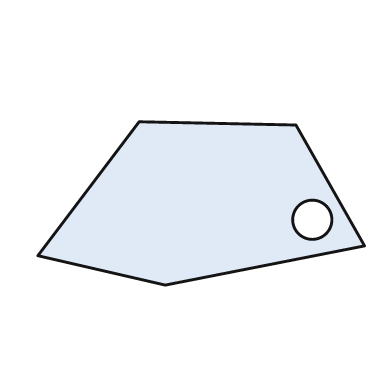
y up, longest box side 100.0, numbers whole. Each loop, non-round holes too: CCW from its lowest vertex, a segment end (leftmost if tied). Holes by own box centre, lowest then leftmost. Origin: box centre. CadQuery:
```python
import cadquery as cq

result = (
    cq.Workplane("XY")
    .moveTo(-11.0, -25.0)
    .lineTo(50.0, -13.0)
    .lineTo(29.0, 24.0)
    .lineTo(-19.0, 25.0)
    .lineTo(-50.0, -16.0)
    .close()
    .moveTo(34.0, -5.0)
    .circle(6.0)
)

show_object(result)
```